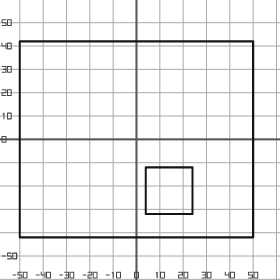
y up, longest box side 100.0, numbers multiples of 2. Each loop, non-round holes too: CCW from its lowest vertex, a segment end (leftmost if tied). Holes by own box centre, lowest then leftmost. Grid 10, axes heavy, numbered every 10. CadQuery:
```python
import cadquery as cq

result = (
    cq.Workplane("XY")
    .moveTo(-50.0, -42.0)
    .lineTo(50.0, -42.0)
    .lineTo(50.0, 42.0)
    .lineTo(-50.0, 42.0)
    .close()
    .moveTo(4.0, -32.0)
    .lineTo(24.0, -32.0)
    .lineTo(24.0, -12.0)
    .lineTo(4.0, -12.0)
    .close()
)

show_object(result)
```